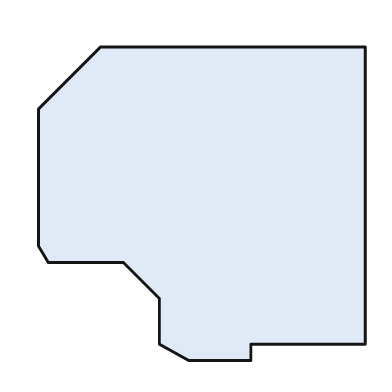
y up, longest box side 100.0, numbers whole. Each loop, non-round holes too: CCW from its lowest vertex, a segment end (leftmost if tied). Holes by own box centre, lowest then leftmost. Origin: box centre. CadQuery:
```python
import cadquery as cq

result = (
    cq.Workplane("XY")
    .moveTo(-4.0, -48.0)
    .lineTo(15.0, -48.0)
    .lineTo(15.0, -43.0)
    .lineTo(50.0, -43.0)
    .lineTo(50.0, 48.0)
    .lineTo(-31.0, 48.0)
    .lineTo(-50.0, 29.0)
    .lineTo(-50.0, -13.0)
    .lineTo(-47.0, -18.0)
    .lineTo(-24.0, -18.0)
    .lineTo(-13.0, -29.0)
    .lineTo(-13.0, -43.0)
    .close()
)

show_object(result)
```